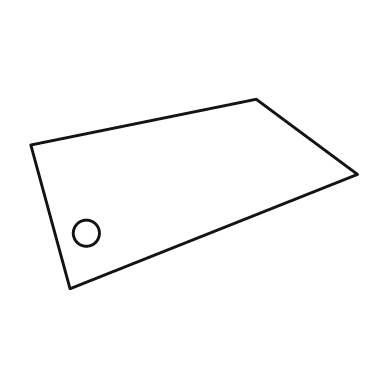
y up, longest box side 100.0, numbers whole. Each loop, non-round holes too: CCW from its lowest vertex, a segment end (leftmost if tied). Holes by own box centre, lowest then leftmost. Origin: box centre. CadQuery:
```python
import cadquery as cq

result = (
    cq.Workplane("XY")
    .moveTo(-38.0, -29.0)
    .lineTo(50.0, 6.0)
    .lineTo(19.0, 29.0)
    .lineTo(-50.0, 15.0)
    .close()
    .moveTo(-33.0, -12.0)
    .circle(4.0)
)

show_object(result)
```